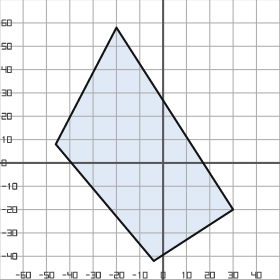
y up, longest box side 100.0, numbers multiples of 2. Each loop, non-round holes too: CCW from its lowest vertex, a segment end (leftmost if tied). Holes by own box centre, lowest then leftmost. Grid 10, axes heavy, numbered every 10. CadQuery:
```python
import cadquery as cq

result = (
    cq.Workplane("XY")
    .moveTo(-4.0, -42.0)
    .lineTo(30.0, -20.0)
    .lineTo(-20.0, 58.0)
    .lineTo(-46.0, 8.0)
    .close()
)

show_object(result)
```